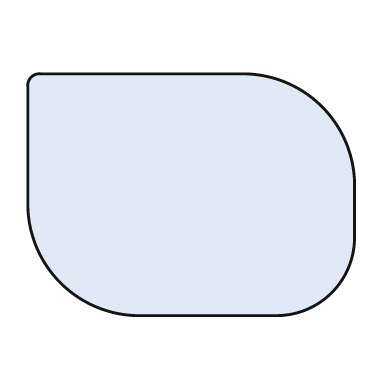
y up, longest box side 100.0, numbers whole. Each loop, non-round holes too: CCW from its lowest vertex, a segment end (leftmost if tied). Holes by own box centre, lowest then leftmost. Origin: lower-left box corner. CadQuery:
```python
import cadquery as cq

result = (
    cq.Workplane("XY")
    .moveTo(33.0, 0.0)
    .lineTo(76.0, 0.0)
    .threePointArc((93.0, 7.0), (100.0, 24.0))
    .lineTo(100.0, 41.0)
    .threePointArc((90.0, 64.0), (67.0, 74.0))
    .lineTo(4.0, 74.0)
    .threePointArc((1.0, 73.0), (0.0, 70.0))
    .lineTo(0.0, 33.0)
    .threePointArc((10.0, 10.0), (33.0, 0.0))
    .close()
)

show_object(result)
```